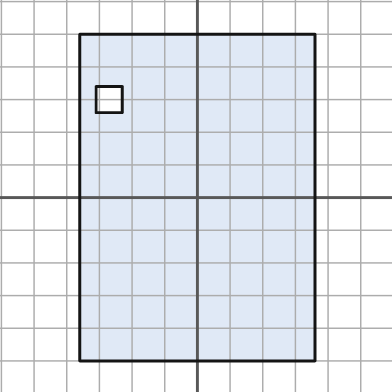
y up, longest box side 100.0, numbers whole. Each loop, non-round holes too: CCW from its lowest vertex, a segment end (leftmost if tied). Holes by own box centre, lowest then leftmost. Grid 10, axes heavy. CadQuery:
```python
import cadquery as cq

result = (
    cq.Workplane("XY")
    .moveTo(-36.0, -50.0)
    .lineTo(36.0, -50.0)
    .lineTo(36.0, 50.0)
    .lineTo(-36.0, 50.0)
    .close()
    .moveTo(-31.0, 26.0)
    .lineTo(-23.0, 26.0)
    .lineTo(-23.0, 34.0)
    .lineTo(-31.0, 34.0)
    .close()
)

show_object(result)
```